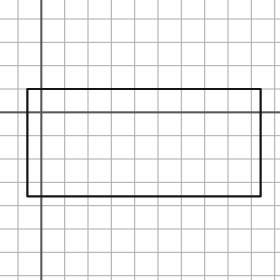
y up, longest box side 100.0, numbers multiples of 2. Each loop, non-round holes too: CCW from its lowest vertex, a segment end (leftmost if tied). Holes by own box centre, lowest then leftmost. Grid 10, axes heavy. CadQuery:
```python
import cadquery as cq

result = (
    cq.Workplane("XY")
    .moveTo(-6.0, -36.0)
    .lineTo(94.0, -36.0)
    .lineTo(94.0, 10.0)
    .lineTo(-6.0, 10.0)
    .close()
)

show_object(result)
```